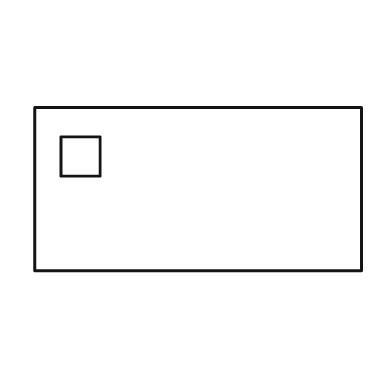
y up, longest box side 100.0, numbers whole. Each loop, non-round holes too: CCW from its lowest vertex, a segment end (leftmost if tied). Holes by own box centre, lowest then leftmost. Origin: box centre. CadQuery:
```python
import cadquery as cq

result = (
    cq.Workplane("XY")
    .moveTo(-50.0, -25.0)
    .lineTo(50.0, -25.0)
    .lineTo(50.0, 25.0)
    .lineTo(-50.0, 25.0)
    .close()
    .moveTo(-42.0, 4.0)
    .lineTo(-30.0, 4.0)
    .lineTo(-30.0, 16.0)
    .lineTo(-42.0, 16.0)
    .close()
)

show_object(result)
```